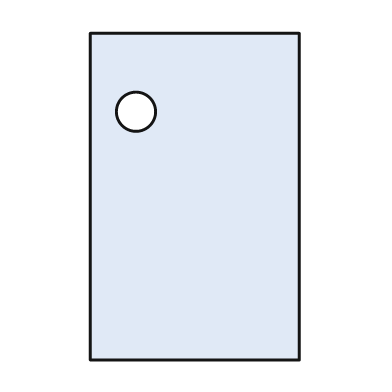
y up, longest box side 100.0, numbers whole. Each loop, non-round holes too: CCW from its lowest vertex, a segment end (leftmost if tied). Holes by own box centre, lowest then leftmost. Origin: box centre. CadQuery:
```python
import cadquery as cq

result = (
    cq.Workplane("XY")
    .moveTo(-32.0, -50.0)
    .lineTo(32.0, -50.0)
    .lineTo(32.0, 50.0)
    .lineTo(-32.0, 50.0)
    .close()
    .moveTo(-18.0, 26.0)
    .circle(6.0)
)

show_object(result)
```